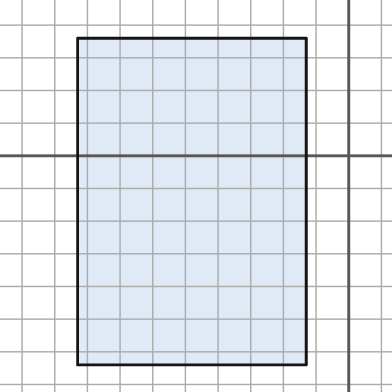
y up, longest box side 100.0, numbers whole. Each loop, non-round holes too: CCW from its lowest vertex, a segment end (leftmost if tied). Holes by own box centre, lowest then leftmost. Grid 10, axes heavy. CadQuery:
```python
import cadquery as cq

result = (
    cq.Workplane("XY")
    .moveTo(-83.0, -64.0)
    .lineTo(-13.0, -64.0)
    .lineTo(-13.0, 36.0)
    .lineTo(-83.0, 36.0)
    .close()
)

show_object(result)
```